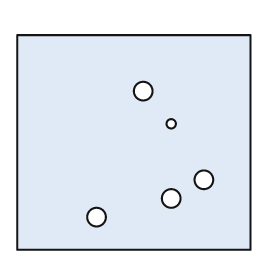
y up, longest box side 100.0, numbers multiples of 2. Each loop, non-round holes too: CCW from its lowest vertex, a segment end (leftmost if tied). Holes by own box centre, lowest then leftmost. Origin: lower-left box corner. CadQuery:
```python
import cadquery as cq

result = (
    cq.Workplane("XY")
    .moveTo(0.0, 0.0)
    .lineTo(100.0, 0.0)
    .lineTo(100.0, 92.0)
    .lineTo(0.0, 92.0)
    .close()
    .moveTo(34.0, 14.0)
    .circle(4.0)
    .moveTo(66.0, 22.0)
    .circle(4.0)
    .moveTo(80.0, 30.0)
    .circle(4.0)
    .moveTo(66.0, 54.0)
    .circle(2.0)
    .moveTo(54.0, 68.0)
    .circle(4.0)
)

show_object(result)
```